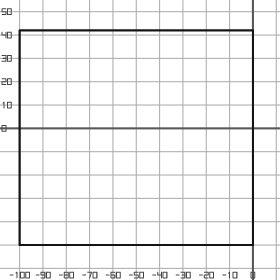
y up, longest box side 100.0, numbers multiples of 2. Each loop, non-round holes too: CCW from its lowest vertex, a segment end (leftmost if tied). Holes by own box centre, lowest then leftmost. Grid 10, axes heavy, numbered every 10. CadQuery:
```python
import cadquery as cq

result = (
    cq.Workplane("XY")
    .moveTo(-100.0, -50.0)
    .lineTo(0.0, -50.0)
    .lineTo(0.0, 42.0)
    .lineTo(-100.0, 42.0)
    .close()
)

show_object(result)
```